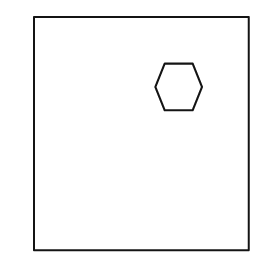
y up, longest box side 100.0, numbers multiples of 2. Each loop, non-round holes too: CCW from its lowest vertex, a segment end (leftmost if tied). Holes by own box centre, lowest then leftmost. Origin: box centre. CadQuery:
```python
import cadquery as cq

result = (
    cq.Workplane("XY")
    .moveTo(-46.0, -50.0)
    .lineTo(46.0, -50.0)
    .lineTo(46.0, 50.0)
    .lineTo(-46.0, 50.0)
    .close()
    .moveTo(10.0, 10.0)
    .lineTo(22.0, 10.0)
    .lineTo(26.0, 20.0)
    .lineTo(22.0, 30.0)
    .lineTo(10.0, 30.0)
    .lineTo(6.0, 20.0)
    .close()
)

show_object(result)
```